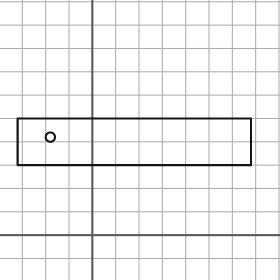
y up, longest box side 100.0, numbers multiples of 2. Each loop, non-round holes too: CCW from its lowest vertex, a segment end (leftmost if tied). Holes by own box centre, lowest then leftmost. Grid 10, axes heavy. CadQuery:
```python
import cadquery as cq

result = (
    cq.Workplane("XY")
    .moveTo(-32.0, 30.0)
    .lineTo(68.0, 30.0)
    .lineTo(68.0, 50.0)
    .lineTo(-32.0, 50.0)
    .close()
    .moveTo(-18.0, 42.0)
    .circle(2.0)
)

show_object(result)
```